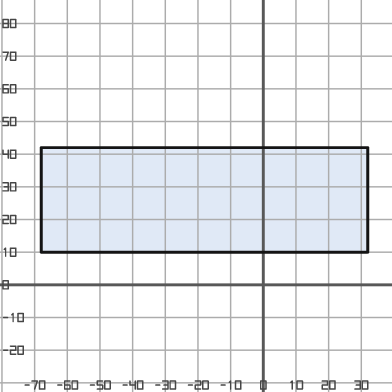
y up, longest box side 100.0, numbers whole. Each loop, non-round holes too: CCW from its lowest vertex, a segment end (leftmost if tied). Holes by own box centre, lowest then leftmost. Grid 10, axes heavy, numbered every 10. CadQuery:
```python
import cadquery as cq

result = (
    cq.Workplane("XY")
    .moveTo(-68.0, 10.0)
    .lineTo(32.0, 10.0)
    .lineTo(32.0, 42.0)
    .lineTo(-68.0, 42.0)
    .close()
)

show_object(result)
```